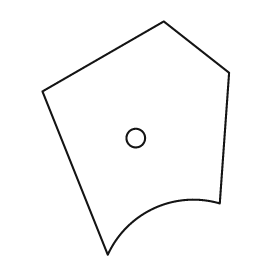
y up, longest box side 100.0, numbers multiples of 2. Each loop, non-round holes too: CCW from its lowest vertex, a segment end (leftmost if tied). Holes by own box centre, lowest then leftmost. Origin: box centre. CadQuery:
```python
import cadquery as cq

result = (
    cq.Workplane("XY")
    .moveTo(-12.0, -50.0)
    .threePointArc((8.0, -30.0), (36.0, -28.0))
    .lineTo(40.0, 28.0)
    .lineTo(12.0, 50.0)
    .lineTo(-40.0, 20.0)
    .close()
    .moveTo(0.0, 0.0)
    .circle(4.0)
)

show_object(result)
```